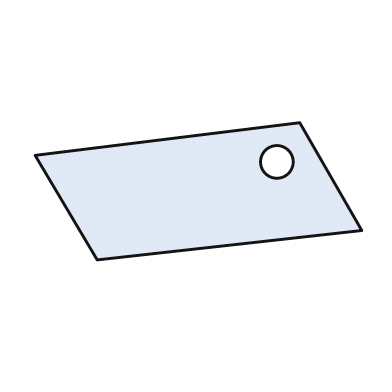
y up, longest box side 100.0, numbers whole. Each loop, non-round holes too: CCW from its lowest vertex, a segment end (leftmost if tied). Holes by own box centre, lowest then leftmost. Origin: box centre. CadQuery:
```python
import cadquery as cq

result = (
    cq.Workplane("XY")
    .moveTo(-31.0, -21.0)
    .lineTo(50.0, -12.0)
    .lineTo(31.0, 21.0)
    .lineTo(-50.0, 11.0)
    .close()
    .moveTo(24.0, 9.0)
    .circle(5.0)
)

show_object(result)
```